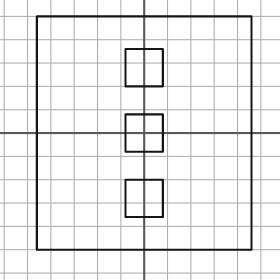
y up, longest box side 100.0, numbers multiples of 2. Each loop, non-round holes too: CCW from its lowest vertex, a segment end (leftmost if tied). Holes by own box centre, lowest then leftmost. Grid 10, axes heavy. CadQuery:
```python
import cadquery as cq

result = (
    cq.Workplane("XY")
    .moveTo(-46.0, -50.0)
    .lineTo(46.0, -50.0)
    .lineTo(46.0, 50.0)
    .lineTo(-46.0, 50.0)
    .close()
    .moveTo(-8.0, -36.0)
    .lineTo(8.0, -36.0)
    .lineTo(8.0, -20.0)
    .lineTo(-8.0, -20.0)
    .close()
    .moveTo(-8.0, -8.0)
    .lineTo(8.0, -8.0)
    .lineTo(8.0, 8.0)
    .lineTo(-8.0, 8.0)
    .close()
    .moveTo(-8.0, 20.0)
    .lineTo(8.0, 20.0)
    .lineTo(8.0, 36.0)
    .lineTo(-8.0, 36.0)
    .close()
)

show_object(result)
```